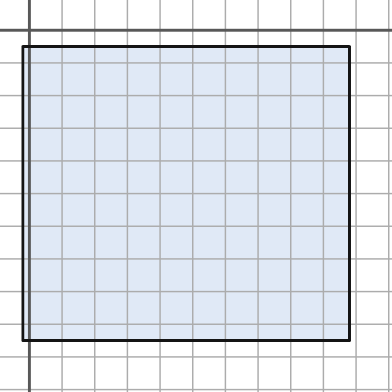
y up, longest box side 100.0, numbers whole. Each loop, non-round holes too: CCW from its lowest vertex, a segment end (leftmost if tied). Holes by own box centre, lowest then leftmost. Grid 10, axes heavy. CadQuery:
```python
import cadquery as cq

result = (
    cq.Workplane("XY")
    .moveTo(-2.0, -95.0)
    .lineTo(98.0, -95.0)
    .lineTo(98.0, -5.0)
    .lineTo(-2.0, -5.0)
    .close()
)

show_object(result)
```